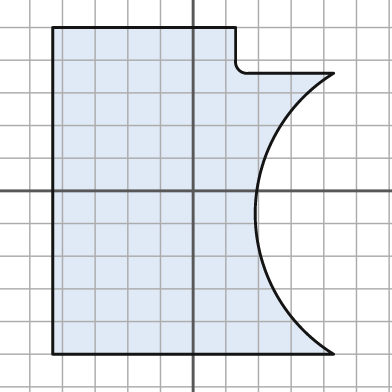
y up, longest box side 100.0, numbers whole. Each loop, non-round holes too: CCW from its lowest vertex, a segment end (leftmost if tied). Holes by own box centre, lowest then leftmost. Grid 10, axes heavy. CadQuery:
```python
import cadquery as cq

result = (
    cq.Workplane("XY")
    .moveTo(-43.0, -50.0)
    .lineTo(43.0, -50.0)
    .threePointArc((19.0, -7.0), (43.0, 36.0))
    .lineTo(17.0, 36.0)
    .threePointArc((14.0, 37.0), (13.0, 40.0))
    .lineTo(13.0, 50.0)
    .lineTo(-43.0, 50.0)
    .close()
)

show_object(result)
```